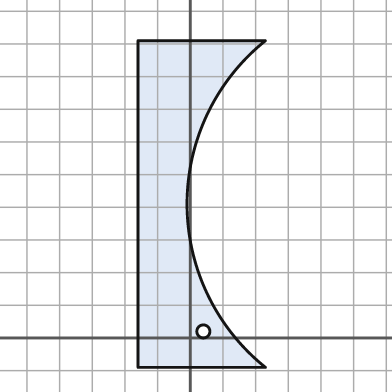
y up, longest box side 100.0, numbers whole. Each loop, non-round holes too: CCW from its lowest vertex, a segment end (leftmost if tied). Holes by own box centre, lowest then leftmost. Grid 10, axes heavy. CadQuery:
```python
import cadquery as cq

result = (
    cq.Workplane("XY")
    .moveTo(-16.0, -9.0)
    .lineTo(23.0, -9.0)
    .threePointArc((-1.0, 41.0), (23.0, 91.0))
    .lineTo(-16.0, 91.0)
    .close()
    .moveTo(4.0, 2.0)
    .circle(2.0)
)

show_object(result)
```